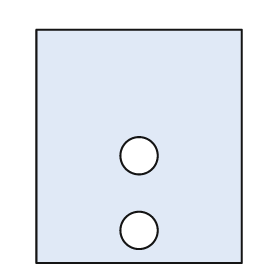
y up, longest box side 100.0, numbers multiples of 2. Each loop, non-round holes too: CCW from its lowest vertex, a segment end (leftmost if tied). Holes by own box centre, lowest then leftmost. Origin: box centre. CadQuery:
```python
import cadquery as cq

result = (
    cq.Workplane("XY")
    .moveTo(-44.0, -50.0)
    .lineTo(44.0, -50.0)
    .lineTo(44.0, 50.0)
    .lineTo(-44.0, 50.0)
    .close()
    .moveTo(0.0, -36.0)
    .circle(8.0)
    .moveTo(0.0, -4.0)
    .circle(8.0)
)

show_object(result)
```